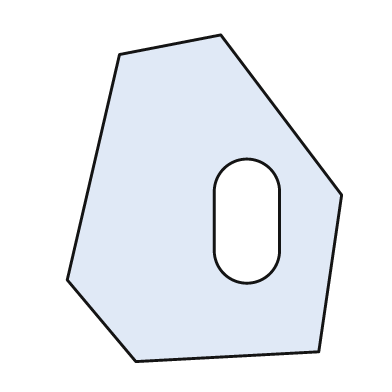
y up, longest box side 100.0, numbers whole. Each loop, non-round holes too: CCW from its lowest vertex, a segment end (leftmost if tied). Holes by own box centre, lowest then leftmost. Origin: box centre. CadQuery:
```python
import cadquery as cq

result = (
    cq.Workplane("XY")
    .moveTo(-21.0, -50.0)
    .lineTo(35.0, -47.0)
    .lineTo(42.0, 1.0)
    .lineTo(5.0, 50.0)
    .lineTo(-26.0, 44.0)
    .lineTo(-42.0, -25.0)
    .close()
    .moveTo(3.0, -16.0)
    .threePointArc((13.0, -26.0), (23.0, -16.0))
    .lineTo(23.0, 2.0)
    .threePointArc((13.0, 12.0), (3.0, 2.0))
    .close()
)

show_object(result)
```